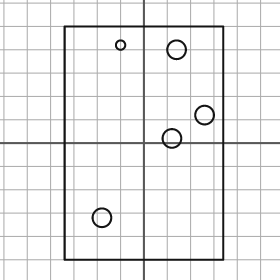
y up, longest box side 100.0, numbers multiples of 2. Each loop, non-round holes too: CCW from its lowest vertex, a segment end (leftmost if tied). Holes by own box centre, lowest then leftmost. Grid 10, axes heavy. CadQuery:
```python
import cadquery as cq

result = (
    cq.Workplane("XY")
    .moveTo(-34.0, -50.0)
    .lineTo(34.0, -50.0)
    .lineTo(34.0, 50.0)
    .lineTo(-34.0, 50.0)
    .close()
    .moveTo(-18.0, -32.0)
    .circle(4.0)
    .moveTo(12.0, 2.0)
    .circle(4.0)
    .moveTo(26.0, 12.0)
    .circle(4.0)
    .moveTo(14.0, 40.0)
    .circle(4.0)
    .moveTo(-10.0, 42.0)
    .circle(2.0)
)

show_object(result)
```